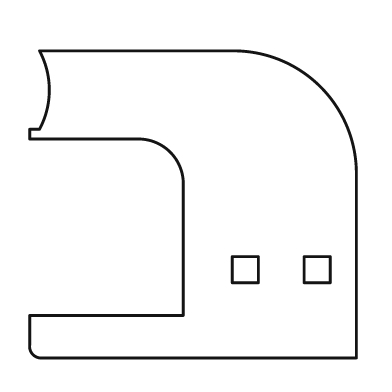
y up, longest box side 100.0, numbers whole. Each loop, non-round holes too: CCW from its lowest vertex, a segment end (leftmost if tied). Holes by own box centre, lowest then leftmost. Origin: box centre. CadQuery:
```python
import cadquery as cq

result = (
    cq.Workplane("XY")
    .moveTo(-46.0, -47.0)
    .lineTo(50.0, -47.0)
    .lineTo(50.0, 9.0)
    .threePointArc((39.0, 36.0), (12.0, 47.0))
    .lineTo(-47.0, 47.0)
    .threePointArc((-44.0, 35.0), (-47.0, 23.0))
    .lineTo(-50.0, 23.0)
    .lineTo(-50.0, 20.0)
    .lineTo(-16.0, 20.0)
    .threePointArc((-7.0, 16.0), (-3.0, 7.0))
    .lineTo(-3.0, -34.0)
    .lineTo(-50.0, -34.0)
    .lineTo(-50.0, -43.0)
    .threePointArc((-49.0, -46.0), (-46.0, -47.0))
    .close()
    .moveTo(12.0, -24.0)
    .lineTo(20.0, -24.0)
    .lineTo(20.0, -16.0)
    .lineTo(12.0, -16.0)
    .close()
    .moveTo(34.0, -24.0)
    .lineTo(42.0, -24.0)
    .lineTo(42.0, -16.0)
    .lineTo(34.0, -16.0)
    .close()
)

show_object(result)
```